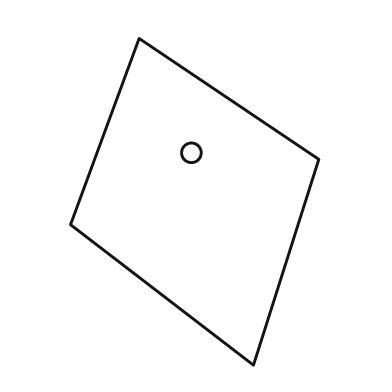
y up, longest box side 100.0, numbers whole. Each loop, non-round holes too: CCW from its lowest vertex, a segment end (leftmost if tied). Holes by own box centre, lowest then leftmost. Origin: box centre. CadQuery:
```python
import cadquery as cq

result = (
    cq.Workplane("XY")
    .moveTo(18.0, -50.0)
    .lineTo(38.0, 13.0)
    .lineTo(-17.0, 50.0)
    .lineTo(-38.0, -7.0)
    .close()
    .moveTo(-1.0, 15.0)
    .circle(3.0)
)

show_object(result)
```